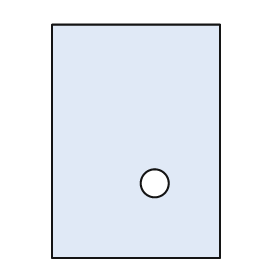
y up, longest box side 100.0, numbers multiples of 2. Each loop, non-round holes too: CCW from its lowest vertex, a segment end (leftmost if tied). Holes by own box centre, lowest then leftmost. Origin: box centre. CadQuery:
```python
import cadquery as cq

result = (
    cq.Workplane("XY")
    .moveTo(-36.0, -50.0)
    .lineTo(36.0, -50.0)
    .lineTo(36.0, 50.0)
    .lineTo(-36.0, 50.0)
    .close()
    .moveTo(8.0, -18.0)
    .circle(6.0)
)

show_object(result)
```